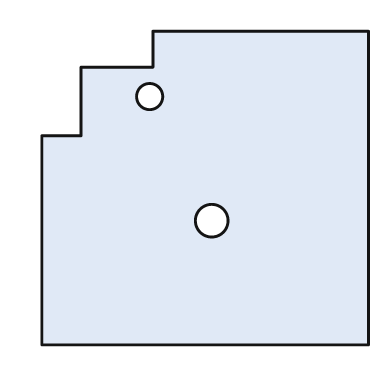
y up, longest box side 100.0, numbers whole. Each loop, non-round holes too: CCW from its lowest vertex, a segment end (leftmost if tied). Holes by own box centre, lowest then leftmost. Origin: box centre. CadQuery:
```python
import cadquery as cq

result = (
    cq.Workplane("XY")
    .moveTo(-50.0, -48.0)
    .lineTo(50.0, -48.0)
    .lineTo(50.0, 48.0)
    .lineTo(-16.0, 48.0)
    .lineTo(-16.0, 37.0)
    .lineTo(-38.0, 37.0)
    .lineTo(-38.0, 16.0)
    .lineTo(-50.0, 16.0)
    .close()
    .moveTo(2.0, -10.0)
    .circle(5.0)
    .moveTo(-17.0, 28.0)
    .circle(4.0)
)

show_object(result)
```